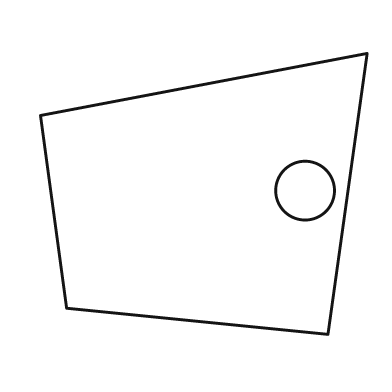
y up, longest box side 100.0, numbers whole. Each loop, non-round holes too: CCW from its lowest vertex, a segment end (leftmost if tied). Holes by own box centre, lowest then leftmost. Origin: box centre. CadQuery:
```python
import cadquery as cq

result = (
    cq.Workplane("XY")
    .moveTo(38.0, -43.0)
    .lineTo(50.0, 43.0)
    .lineTo(-50.0, 24.0)
    .lineTo(-42.0, -35.0)
    .close()
    .moveTo(31.0, 1.0)
    .circle(9.0)
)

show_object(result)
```